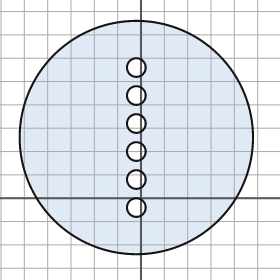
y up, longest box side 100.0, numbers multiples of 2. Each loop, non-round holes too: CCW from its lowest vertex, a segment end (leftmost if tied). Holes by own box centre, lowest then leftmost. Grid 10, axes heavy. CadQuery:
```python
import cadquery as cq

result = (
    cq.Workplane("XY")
    .moveTo(-2.0, 26.0)
    .circle(50.0)
    .moveTo(-2.0, -4.0)
    .circle(4.0)
    .moveTo(-2.0, 8.0)
    .circle(4.0)
    .moveTo(-2.0, 20.0)
    .circle(4.0)
    .moveTo(-2.0, 32.0)
    .circle(4.0)
    .moveTo(-2.0, 44.0)
    .circle(4.0)
    .moveTo(-2.0, 56.0)
    .circle(4.0)
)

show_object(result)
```